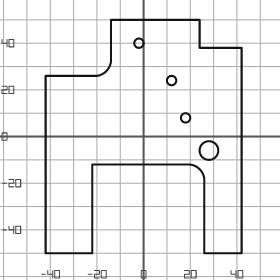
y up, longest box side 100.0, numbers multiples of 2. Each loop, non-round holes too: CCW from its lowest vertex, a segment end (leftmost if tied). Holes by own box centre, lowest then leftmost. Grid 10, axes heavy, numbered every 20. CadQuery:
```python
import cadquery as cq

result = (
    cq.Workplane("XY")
    .moveTo(-42.0, -50.0)
    .lineTo(-22.0, -50.0)
    .lineTo(-22.0, -12.0)
    .lineTo(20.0, -12.0)
    .threePointArc((24.0, -14.0), (26.0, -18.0))
    .lineTo(26.0, -50.0)
    .lineTo(42.0, -50.0)
    .lineTo(42.0, 38.0)
    .lineTo(24.0, 38.0)
    .lineTo(24.0, 50.0)
    .lineTo(-14.0, 50.0)
    .lineTo(-14.0, 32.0)
    .threePointArc((-16.0, 28.0), (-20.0, 26.0))
    .lineTo(-42.0, 26.0)
    .close()
    .moveTo(28.0, -6.0)
    .circle(4.0)
    .moveTo(18.0, 8.0)
    .circle(2.0)
    .moveTo(12.0, 24.0)
    .circle(2.0)
    .moveTo(-2.0, 40.0)
    .circle(2.0)
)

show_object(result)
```